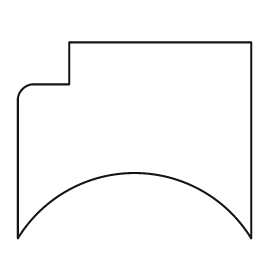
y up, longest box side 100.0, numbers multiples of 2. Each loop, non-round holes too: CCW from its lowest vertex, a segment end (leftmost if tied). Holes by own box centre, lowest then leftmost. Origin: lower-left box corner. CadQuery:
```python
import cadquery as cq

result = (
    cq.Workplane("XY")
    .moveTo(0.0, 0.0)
    .threePointArc((50.0, 28.0), (100.0, 0.0))
    .lineTo(100.0, 84.0)
    .lineTo(22.0, 84.0)
    .lineTo(22.0, 66.0)
    .lineTo(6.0, 66.0)
    .threePointArc((2.0, 64.0), (0.0, 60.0))
    .close()
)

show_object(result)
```